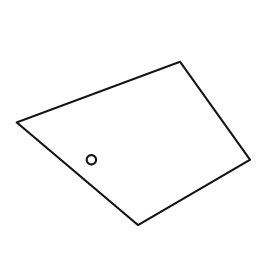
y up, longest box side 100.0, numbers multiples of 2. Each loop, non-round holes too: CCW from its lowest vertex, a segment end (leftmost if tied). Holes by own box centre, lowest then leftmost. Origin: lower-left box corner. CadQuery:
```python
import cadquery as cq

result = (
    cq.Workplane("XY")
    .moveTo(52.0, 0.0)
    .lineTo(100.0, 28.0)
    .lineTo(70.0, 70.0)
    .lineTo(0.0, 44.0)
    .close()
    .moveTo(32.0, 28.0)
    .circle(2.0)
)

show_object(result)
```